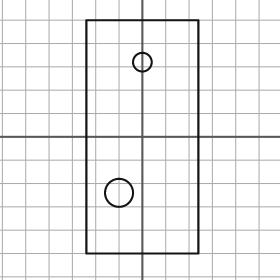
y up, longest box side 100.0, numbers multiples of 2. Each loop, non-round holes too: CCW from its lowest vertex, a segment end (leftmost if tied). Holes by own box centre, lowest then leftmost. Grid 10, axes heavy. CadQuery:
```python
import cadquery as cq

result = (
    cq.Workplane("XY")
    .moveTo(-24.0, -50.0)
    .lineTo(24.0, -50.0)
    .lineTo(24.0, 50.0)
    .lineTo(-24.0, 50.0)
    .close()
    .moveTo(-10.0, -24.0)
    .circle(6.0)
    .moveTo(0.0, 32.0)
    .circle(4.0)
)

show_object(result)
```